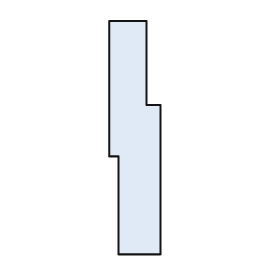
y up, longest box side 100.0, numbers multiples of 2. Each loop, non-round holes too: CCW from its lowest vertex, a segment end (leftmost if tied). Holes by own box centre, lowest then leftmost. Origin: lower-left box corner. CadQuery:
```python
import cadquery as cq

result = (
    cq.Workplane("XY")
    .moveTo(4.0, 0.0)
    .lineTo(22.0, 0.0)
    .lineTo(22.0, 64.0)
    .lineTo(16.0, 64.0)
    .lineTo(16.0, 100.0)
    .lineTo(0.0, 100.0)
    .lineTo(0.0, 42.0)
    .lineTo(4.0, 42.0)
    .close()
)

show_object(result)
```